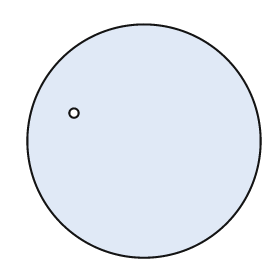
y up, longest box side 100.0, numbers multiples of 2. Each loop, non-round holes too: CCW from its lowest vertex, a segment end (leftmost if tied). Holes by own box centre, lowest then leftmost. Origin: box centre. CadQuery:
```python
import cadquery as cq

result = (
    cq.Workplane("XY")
    .moveTo(0.0, 0.0)
    .circle(50.0)
    .moveTo(-30.0, 12.0)
    .circle(2.0)
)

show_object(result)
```